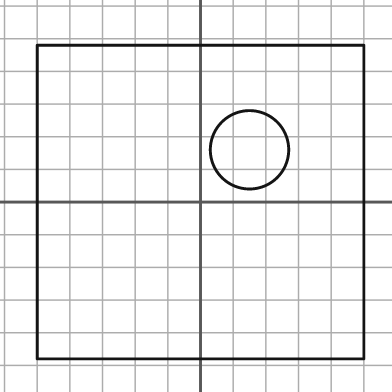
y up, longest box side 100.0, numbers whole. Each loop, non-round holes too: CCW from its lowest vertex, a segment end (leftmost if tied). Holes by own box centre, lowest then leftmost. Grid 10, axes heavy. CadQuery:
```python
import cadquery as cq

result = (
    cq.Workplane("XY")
    .moveTo(-50.0, -48.0)
    .lineTo(50.0, -48.0)
    .lineTo(50.0, 48.0)
    .lineTo(-50.0, 48.0)
    .close()
    .moveTo(15.0, 16.0)
    .circle(12.0)
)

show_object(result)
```